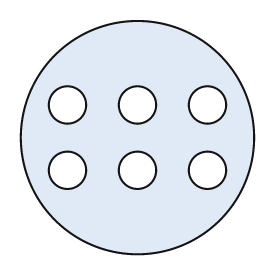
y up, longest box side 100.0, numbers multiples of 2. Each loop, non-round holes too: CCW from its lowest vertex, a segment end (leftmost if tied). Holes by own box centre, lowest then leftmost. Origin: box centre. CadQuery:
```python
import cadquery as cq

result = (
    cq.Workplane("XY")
    .moveTo(0.0, 0.0)
    .circle(50.0)
    .moveTo(-30.0, -14.0)
    .circle(8.0)
    .moveTo(0.0, -14.0)
    .circle(8.0)
    .moveTo(30.0, -14.0)
    .circle(8.0)
    .moveTo(-30.0, 14.0)
    .circle(8.0)
    .moveTo(0.0, 14.0)
    .circle(8.0)
    .moveTo(30.0, 14.0)
    .circle(8.0)
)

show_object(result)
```